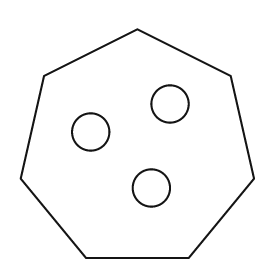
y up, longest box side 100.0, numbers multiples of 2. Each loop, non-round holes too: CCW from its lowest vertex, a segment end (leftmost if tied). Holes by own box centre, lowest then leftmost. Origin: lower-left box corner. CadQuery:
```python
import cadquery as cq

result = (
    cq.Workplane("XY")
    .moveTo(28.0, 0.0)
    .lineTo(72.0, 0.0)
    .lineTo(100.0, 34.0)
    .lineTo(90.0, 78.0)
    .lineTo(50.0, 98.0)
    .lineTo(10.0, 78.0)
    .lineTo(0.0, 34.0)
    .close()
    .moveTo(56.0, 30.0)
    .circle(8.0)
    .moveTo(30.0, 54.0)
    .circle(8.0)
    .moveTo(64.0, 66.0)
    .circle(8.0)
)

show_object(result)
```